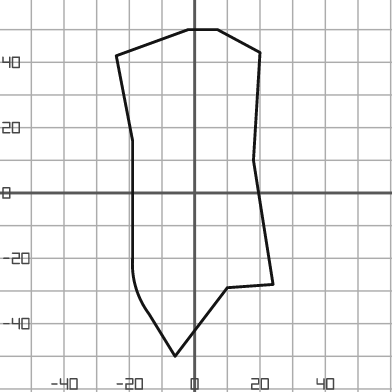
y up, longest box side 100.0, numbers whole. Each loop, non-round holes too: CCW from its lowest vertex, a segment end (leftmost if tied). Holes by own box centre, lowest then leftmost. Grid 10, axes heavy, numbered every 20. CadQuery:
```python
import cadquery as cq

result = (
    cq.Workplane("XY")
    .moveTo(-6.0, -50.0)
    .lineTo(10.0, -29.0)
    .lineTo(24.0, -28.0)
    .lineTo(18.0, 10.0)
    .lineTo(20.0, 43.0)
    .lineTo(7.0, 50.0)
    .lineTo(-2.0, 50.0)
    .lineTo(-24.0, 42.0)
    .lineTo(-19.0, 16.0)
    .lineTo(-19.0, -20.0)
    .threePointArc((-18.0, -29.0), (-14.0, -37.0))
    .close()
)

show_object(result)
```